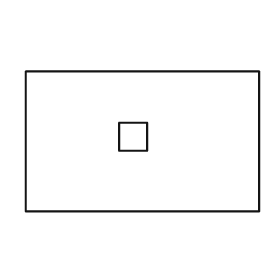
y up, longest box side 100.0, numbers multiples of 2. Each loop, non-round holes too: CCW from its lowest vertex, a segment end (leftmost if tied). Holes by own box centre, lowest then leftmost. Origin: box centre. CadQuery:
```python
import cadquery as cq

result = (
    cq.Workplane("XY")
    .moveTo(-50.0, -30.0)
    .lineTo(50.0, -30.0)
    .lineTo(50.0, 30.0)
    .lineTo(-50.0, 30.0)
    .close()
    .moveTo(-10.0, -4.0)
    .lineTo(2.0, -4.0)
    .lineTo(2.0, 8.0)
    .lineTo(-10.0, 8.0)
    .close()
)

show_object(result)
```